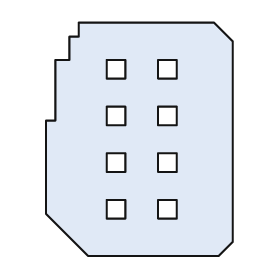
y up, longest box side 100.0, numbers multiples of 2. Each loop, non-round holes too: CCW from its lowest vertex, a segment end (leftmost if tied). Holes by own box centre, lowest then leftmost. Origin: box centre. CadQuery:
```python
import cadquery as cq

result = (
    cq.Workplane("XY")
    .moveTo(-22.0, -50.0)
    .lineTo(34.0, -50.0)
    .lineTo(40.0, -44.0)
    .lineTo(40.0, 42.0)
    .lineTo(32.0, 50.0)
    .lineTo(-26.0, 50.0)
    .lineTo(-26.0, 44.0)
    .lineTo(-30.0, 44.0)
    .lineTo(-30.0, 34.0)
    .lineTo(-36.0, 34.0)
    .lineTo(-36.0, 8.0)
    .lineTo(-40.0, 8.0)
    .lineTo(-40.0, -32.0)
    .close()
    .moveTo(-14.0, -34.0)
    .lineTo(-6.0, -34.0)
    .lineTo(-6.0, -26.0)
    .lineTo(-14.0, -26.0)
    .close()
    .moveTo(8.0, -34.0)
    .lineTo(16.0, -34.0)
    .lineTo(16.0, -26.0)
    .lineTo(8.0, -26.0)
    .close()
    .moveTo(-14.0, -14.0)
    .lineTo(-6.0, -14.0)
    .lineTo(-6.0, -6.0)
    .lineTo(-14.0, -6.0)
    .close()
    .moveTo(8.0, -14.0)
    .lineTo(16.0, -14.0)
    .lineTo(16.0, -6.0)
    .lineTo(8.0, -6.0)
    .close()
    .moveTo(-14.0, 6.0)
    .lineTo(-6.0, 6.0)
    .lineTo(-6.0, 14.0)
    .lineTo(-14.0, 14.0)
    .close()
    .moveTo(8.0, 6.0)
    .lineTo(16.0, 6.0)
    .lineTo(16.0, 14.0)
    .lineTo(8.0, 14.0)
    .close()
    .moveTo(-14.0, 26.0)
    .lineTo(-6.0, 26.0)
    .lineTo(-6.0, 34.0)
    .lineTo(-14.0, 34.0)
    .close()
    .moveTo(8.0, 26.0)
    .lineTo(16.0, 26.0)
    .lineTo(16.0, 34.0)
    .lineTo(8.0, 34.0)
    .close()
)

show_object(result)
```